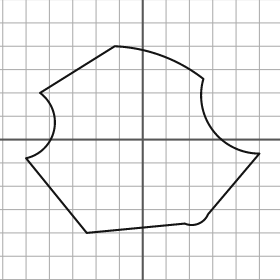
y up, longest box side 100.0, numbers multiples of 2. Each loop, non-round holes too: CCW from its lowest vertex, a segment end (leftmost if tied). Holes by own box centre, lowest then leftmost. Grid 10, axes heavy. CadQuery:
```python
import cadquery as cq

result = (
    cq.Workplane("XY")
    .moveTo(-24.0, -40.0)
    .lineTo(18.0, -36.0)
    .threePointArc((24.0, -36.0), (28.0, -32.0))
    .lineTo(50.0, -6.0)
    .threePointArc((30.0, 4.0), (26.0, 26.0))
    .threePointArc((8.0, 36.0), (-12.0, 40.0))
    .lineTo(-44.0, 20.0)
    .threePointArc((-38.0, 4.0), (-50.0, -8.0))
    .close()
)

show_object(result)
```